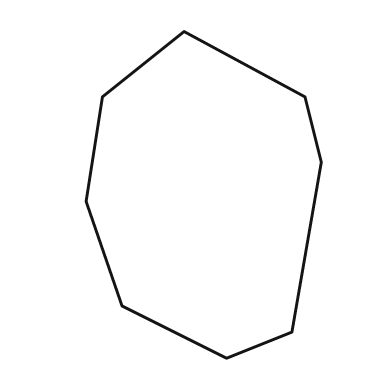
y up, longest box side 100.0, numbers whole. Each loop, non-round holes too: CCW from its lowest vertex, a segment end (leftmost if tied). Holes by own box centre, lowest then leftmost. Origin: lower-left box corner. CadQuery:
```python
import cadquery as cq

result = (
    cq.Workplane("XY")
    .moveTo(43.0, 0.0)
    .lineTo(63.0, 8.0)
    .lineTo(72.0, 60.0)
    .lineTo(67.0, 80.0)
    .lineTo(30.0, 100.0)
    .lineTo(5.0, 80.0)
    .lineTo(0.0, 48.0)
    .lineTo(11.0, 16.0)
    .close()
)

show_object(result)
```